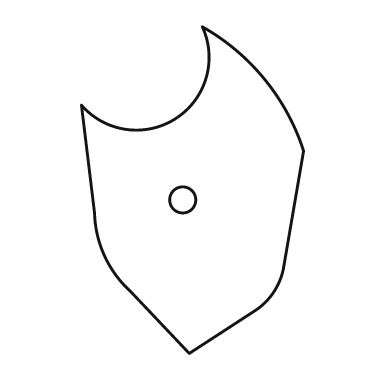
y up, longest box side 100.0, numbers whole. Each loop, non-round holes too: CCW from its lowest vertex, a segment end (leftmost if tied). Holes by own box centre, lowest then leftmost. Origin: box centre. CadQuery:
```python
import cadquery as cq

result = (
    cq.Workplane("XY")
    .moveTo(-1.0, -50.0)
    .lineTo(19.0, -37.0)
    .threePointArc((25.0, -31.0), (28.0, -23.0))
    .lineTo(34.0, 12.0)
    .threePointArc((22.0, 34.0), (3.0, 50.0))
    .threePointArc((-5.0, 22.0), (-34.0, 26.0))
    .lineTo(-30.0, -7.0)
    .threePointArc((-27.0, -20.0), (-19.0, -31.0))
    .close()
    .moveTo(-3.0, -3.0)
    .circle(4.0)
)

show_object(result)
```